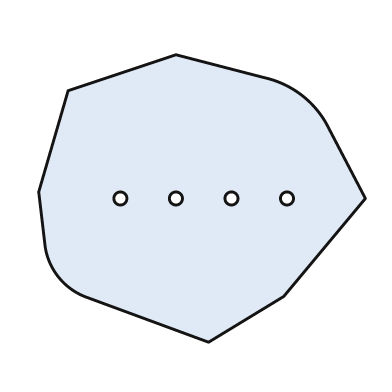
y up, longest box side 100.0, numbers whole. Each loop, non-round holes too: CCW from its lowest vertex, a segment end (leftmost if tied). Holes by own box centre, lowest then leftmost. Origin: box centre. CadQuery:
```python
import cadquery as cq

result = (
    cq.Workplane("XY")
    .moveTo(2.0, -44.0)
    .lineTo(25.0, -30.0)
    .lineTo(50.0, 0.0)
    .lineTo(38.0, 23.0)
    .threePointArc((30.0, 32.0), (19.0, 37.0))
    .lineTo(-8.0, 44.0)
    .lineTo(-41.0, 33.0)
    .lineTo(-50.0, 2.0)
    .lineTo(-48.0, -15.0)
    .threePointArc((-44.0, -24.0), (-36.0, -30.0))
    .close()
    .moveTo(-25.0, 0.0)
    .circle(2.0)
    .moveTo(-8.0, 0.0)
    .circle(2.0)
    .moveTo(9.0, 0.0)
    .circle(2.0)
    .moveTo(26.0, 0.0)
    .circle(2.0)
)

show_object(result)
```